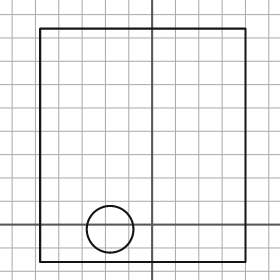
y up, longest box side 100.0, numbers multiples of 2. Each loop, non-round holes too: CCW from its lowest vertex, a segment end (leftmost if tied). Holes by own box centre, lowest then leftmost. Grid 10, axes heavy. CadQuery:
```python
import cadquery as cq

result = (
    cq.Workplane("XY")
    .moveTo(-48.0, -16.0)
    .lineTo(40.0, -16.0)
    .lineTo(40.0, 84.0)
    .lineTo(-48.0, 84.0)
    .close()
    .moveTo(-18.0, -2.0)
    .circle(10.0)
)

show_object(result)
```